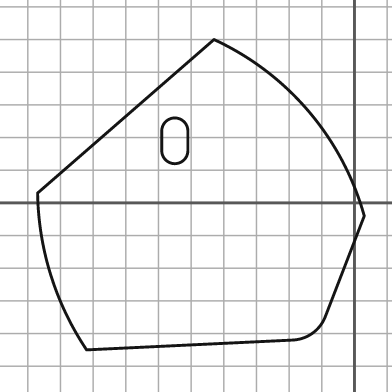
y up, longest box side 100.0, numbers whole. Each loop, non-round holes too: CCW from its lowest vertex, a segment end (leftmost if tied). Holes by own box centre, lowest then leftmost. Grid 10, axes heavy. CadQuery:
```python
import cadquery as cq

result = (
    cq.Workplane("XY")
    .moveTo(-82.0, -45.0)
    .lineTo(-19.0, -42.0)
    .threePointArc((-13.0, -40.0), (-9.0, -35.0))
    .lineTo(3.0, -4.0)
    .threePointArc((-14.0, 28.0), (-43.0, 50.0))
    .lineTo(-97.0, 3.0)
    .threePointArc((-93.0, -22.0), (-82.0, -45.0))
    .close()
    .moveTo(-59.0, 16.0)
    .threePointArc((-55.0, 12.0), (-51.0, 16.0))
    .lineTo(-51.0, 22.0)
    .threePointArc((-55.0, 26.0), (-59.0, 22.0))
    .close()
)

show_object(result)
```